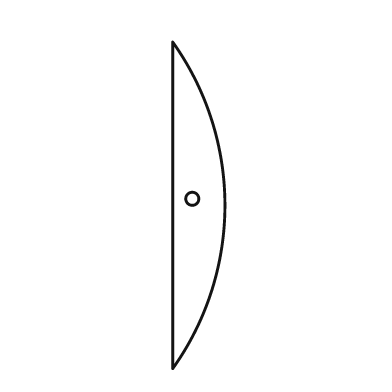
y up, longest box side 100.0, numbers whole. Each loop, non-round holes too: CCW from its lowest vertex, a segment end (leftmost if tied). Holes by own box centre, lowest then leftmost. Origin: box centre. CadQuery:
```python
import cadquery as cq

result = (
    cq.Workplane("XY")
    .moveTo(-8.0, -50.0)
    .threePointArc((8.0, 0.0), (-8.0, 50.0))
    .close()
    .moveTo(-2.0, 2.0)
    .circle(2.0)
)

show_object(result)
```